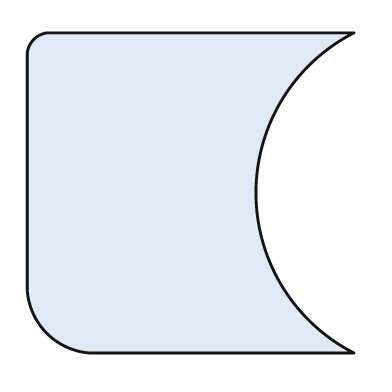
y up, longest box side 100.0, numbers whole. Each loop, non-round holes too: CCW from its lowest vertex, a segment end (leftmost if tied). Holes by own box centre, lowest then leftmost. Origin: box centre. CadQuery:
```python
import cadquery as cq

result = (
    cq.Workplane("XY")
    .moveTo(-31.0, -49.0)
    .lineTo(50.0, -49.0)
    .threePointArc((20.0, 0.0), (50.0, 49.0))
    .lineTo(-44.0, 49.0)
    .threePointArc((-48.0, 47.0), (-50.0, 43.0))
    .lineTo(-50.0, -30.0)
    .threePointArc((-44.0, -43.0), (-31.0, -49.0))
    .close()
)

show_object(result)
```